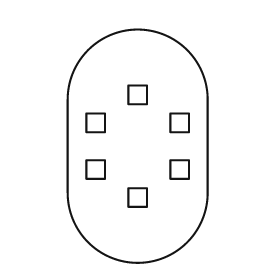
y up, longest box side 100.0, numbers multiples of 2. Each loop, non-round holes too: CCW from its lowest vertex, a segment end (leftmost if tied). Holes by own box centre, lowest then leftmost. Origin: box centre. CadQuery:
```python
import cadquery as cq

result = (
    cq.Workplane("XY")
    .moveTo(-30.0, -20.0)
    .threePointArc((0.0, -50.0), (30.0, -20.0))
    .lineTo(30.0, 20.0)
    .threePointArc((0.0, 50.0), (-30.0, 20.0))
    .close()
    .moveTo(-4.0, -26.0)
    .lineTo(4.0, -26.0)
    .lineTo(4.0, -18.0)
    .lineTo(-4.0, -18.0)
    .close()
    .moveTo(-22.0, -14.0)
    .lineTo(-14.0, -14.0)
    .lineTo(-14.0, -6.0)
    .lineTo(-22.0, -6.0)
    .close()
    .moveTo(14.0, -14.0)
    .lineTo(22.0, -14.0)
    .lineTo(22.0, -6.0)
    .lineTo(14.0, -6.0)
    .close()
    .moveTo(-22.0, 6.0)
    .lineTo(-14.0, 6.0)
    .lineTo(-14.0, 14.0)
    .lineTo(-22.0, 14.0)
    .close()
    .moveTo(14.0, 6.0)
    .lineTo(22.0, 6.0)
    .lineTo(22.0, 14.0)
    .lineTo(14.0, 14.0)
    .close()
    .moveTo(-4.0, 18.0)
    .lineTo(4.0, 18.0)
    .lineTo(4.0, 26.0)
    .lineTo(-4.0, 26.0)
    .close()
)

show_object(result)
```